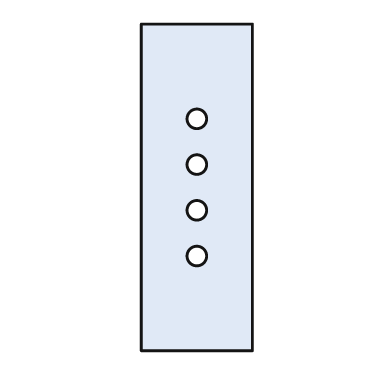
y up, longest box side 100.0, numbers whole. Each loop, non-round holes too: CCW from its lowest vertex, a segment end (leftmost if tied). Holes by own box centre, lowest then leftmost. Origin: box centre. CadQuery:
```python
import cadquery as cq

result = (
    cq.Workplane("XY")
    .moveTo(-17.0, -50.0)
    .lineTo(17.0, -50.0)
    .lineTo(17.0, 50.0)
    .lineTo(-17.0, 50.0)
    .close()
    .moveTo(0.0, -21.0)
    .circle(3.0)
    .moveTo(0.0, -7.0)
    .circle(3.0)
    .moveTo(0.0, 7.0)
    .circle(3.0)
    .moveTo(0.0, 21.0)
    .circle(3.0)
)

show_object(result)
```